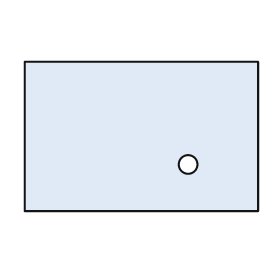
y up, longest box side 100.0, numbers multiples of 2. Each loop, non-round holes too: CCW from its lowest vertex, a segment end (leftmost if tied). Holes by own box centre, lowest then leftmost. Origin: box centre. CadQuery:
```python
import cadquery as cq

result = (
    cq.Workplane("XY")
    .moveTo(-50.0, -32.0)
    .lineTo(50.0, -32.0)
    .lineTo(50.0, 32.0)
    .lineTo(-50.0, 32.0)
    .close()
    .moveTo(20.0, -12.0)
    .circle(4.0)
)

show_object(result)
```